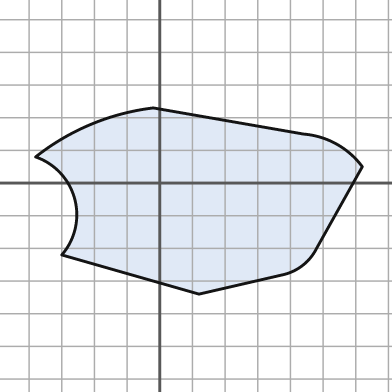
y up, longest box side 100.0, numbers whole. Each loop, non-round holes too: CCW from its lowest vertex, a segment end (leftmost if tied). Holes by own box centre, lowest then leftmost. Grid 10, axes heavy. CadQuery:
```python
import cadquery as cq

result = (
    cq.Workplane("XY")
    .moveTo(12.0, -34.0)
    .lineTo(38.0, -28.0)
    .threePointArc((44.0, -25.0), (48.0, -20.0))
    .lineTo(62.0, 5.0)
    .threePointArc((54.0, 12.0), (44.0, 15.0))
    .lineTo(-2.0, 23.0)
    .threePointArc((-21.0, 18.0), (-38.0, 8.0))
    .threePointArc((-26.0, -5.0), (-30.0, -22.0))
    .close()
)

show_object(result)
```